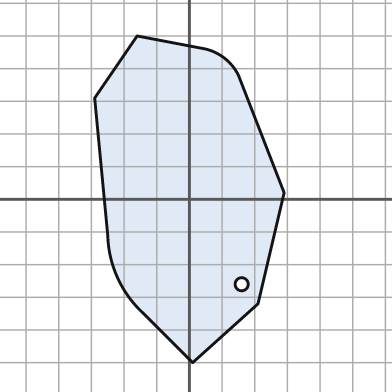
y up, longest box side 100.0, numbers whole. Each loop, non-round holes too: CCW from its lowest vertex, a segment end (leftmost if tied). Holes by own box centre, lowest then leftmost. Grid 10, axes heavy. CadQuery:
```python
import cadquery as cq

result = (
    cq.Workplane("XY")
    .moveTo(1.0, -50.0)
    .lineTo(21.0, -32.0)
    .lineTo(29.0, 2.0)
    .lineTo(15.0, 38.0)
    .threePointArc((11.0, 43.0), (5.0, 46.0))
    .lineTo(-16.0, 50.0)
    .lineTo(-29.0, 31.0)
    .lineTo(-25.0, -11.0)
    .threePointArc((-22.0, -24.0), (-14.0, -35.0))
    .close()
    .moveTo(16.0, -26.0)
    .circle(2.0)
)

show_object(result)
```